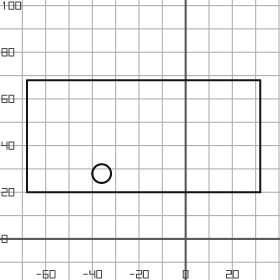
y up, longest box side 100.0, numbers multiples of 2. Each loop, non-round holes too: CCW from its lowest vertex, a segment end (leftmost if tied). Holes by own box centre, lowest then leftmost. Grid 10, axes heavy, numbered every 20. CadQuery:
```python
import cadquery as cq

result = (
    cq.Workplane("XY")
    .moveTo(-68.0, 20.0)
    .lineTo(32.0, 20.0)
    .lineTo(32.0, 68.0)
    .lineTo(-68.0, 68.0)
    .close()
    .moveTo(-36.0, 28.0)
    .circle(4.0)
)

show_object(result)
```